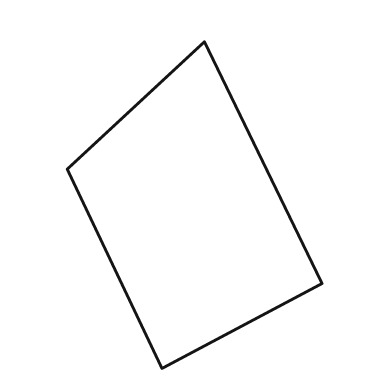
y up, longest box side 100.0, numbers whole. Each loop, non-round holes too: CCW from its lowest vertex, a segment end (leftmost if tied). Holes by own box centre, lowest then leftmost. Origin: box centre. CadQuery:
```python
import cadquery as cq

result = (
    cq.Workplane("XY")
    .moveTo(-10.0, -50.0)
    .lineTo(39.0, -24.0)
    .lineTo(3.0, 50.0)
    .lineTo(-39.0, 11.0)
    .close()
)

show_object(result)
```